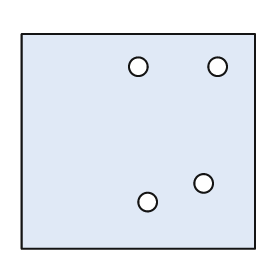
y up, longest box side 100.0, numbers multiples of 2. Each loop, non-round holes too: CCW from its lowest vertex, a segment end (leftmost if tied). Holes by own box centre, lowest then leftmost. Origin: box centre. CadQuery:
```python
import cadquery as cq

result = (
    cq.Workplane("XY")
    .moveTo(-50.0, -46.0)
    .lineTo(50.0, -46.0)
    .lineTo(50.0, 46.0)
    .lineTo(-50.0, 46.0)
    .close()
    .moveTo(4.0, -26.0)
    .circle(4.0)
    .moveTo(28.0, -18.0)
    .circle(4.0)
    .moveTo(0.0, 32.0)
    .circle(4.0)
    .moveTo(34.0, 32.0)
    .circle(4.0)
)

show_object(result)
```